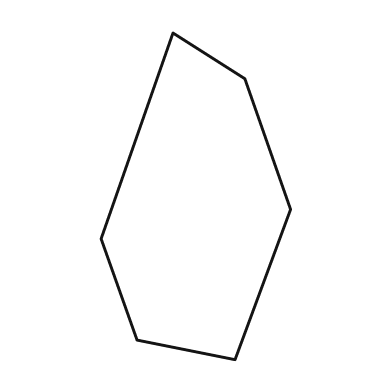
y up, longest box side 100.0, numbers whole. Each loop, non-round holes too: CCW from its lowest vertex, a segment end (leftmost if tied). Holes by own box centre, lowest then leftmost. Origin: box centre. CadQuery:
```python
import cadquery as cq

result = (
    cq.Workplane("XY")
    .moveTo(12.0, -50.0)
    .lineTo(29.0, -4.0)
    .lineTo(15.0, 36.0)
    .lineTo(-7.0, 50.0)
    .lineTo(-29.0, -13.0)
    .lineTo(-18.0, -44.0)
    .close()
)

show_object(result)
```